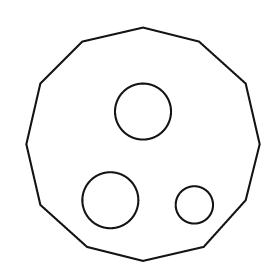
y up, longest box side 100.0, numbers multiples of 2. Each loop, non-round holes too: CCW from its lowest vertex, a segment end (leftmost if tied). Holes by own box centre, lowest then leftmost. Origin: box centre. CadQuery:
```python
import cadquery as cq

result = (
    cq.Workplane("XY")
    .moveTo(0.0, -50.0)
    .lineTo(26.0, -44.0)
    .lineTo(44.0, -24.0)
    .lineTo(50.0, 0.0)
    .lineTo(44.0, 26.0)
    .lineTo(24.0, 44.0)
    .lineTo(0.0, 50.0)
    .lineTo(-26.0, 44.0)
    .lineTo(-44.0, 26.0)
    .lineTo(-50.0, 0.0)
    .lineTo(-44.0, -26.0)
    .lineTo(-24.0, -44.0)
    .close()
    .moveTo(22.0, -26.0)
    .circle(8.0)
    .moveTo(-14.0, -24.0)
    .circle(12.0)
    .moveTo(0.0, 14.0)
    .circle(12.0)
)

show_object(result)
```